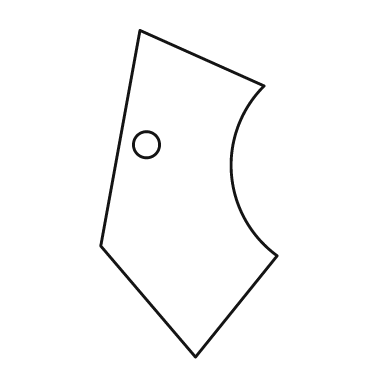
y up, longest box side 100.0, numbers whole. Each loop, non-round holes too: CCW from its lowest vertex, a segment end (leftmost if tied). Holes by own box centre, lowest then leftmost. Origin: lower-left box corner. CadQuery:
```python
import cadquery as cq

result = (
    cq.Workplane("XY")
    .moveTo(29.0, 0.0)
    .lineTo(54.0, 31.0)
    .threePointArc((40.0, 56.0), (50.0, 83.0))
    .lineTo(12.0, 100.0)
    .lineTo(0.0, 34.0)
    .close()
    .moveTo(14.0, 65.0)
    .circle(4.0)
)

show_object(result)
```